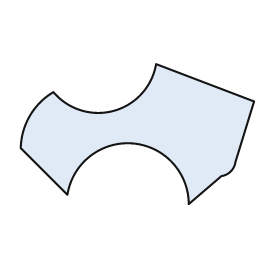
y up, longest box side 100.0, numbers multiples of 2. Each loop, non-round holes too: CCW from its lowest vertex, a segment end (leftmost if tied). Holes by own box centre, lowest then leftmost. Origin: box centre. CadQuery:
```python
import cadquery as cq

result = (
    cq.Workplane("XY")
    .moveTo(22.0, -30.0)
    .lineTo(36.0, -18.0)
    .threePointArc((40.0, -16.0), (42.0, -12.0))
    .lineTo(50.0, 14.0)
    .lineTo(8.0, 30.0)
    .threePointArc((-10.0, 10.0), (-36.0, 18.0))
    .threePointArc((-46.0, 8.0), (-50.0, -6.0))
    .lineTo(-30.0, -26.0)
    .threePointArc((-2.0, -4.0), (22.0, -30.0))
    .close()
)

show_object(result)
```